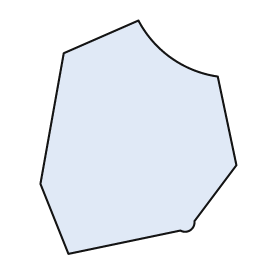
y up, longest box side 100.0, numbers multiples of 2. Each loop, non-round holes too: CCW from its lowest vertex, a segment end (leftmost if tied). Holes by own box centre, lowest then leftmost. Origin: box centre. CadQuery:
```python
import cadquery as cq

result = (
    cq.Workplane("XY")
    .moveTo(-30.0, -50.0)
    .lineTo(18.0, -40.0)
    .threePointArc((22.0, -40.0), (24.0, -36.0))
    .lineTo(42.0, -12.0)
    .lineTo(34.0, 26.0)
    .threePointArc((14.0, 34.0), (0.0, 50.0))
    .lineTo(-32.0, 36.0)
    .lineTo(-42.0, -20.0)
    .close()
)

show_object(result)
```